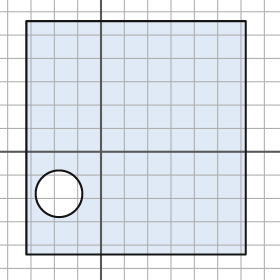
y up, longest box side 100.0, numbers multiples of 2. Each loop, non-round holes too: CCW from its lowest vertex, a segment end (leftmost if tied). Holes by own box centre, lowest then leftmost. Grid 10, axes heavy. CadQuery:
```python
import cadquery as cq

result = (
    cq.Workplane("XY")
    .moveTo(-32.0, -44.0)
    .lineTo(62.0, -44.0)
    .lineTo(62.0, 56.0)
    .lineTo(-32.0, 56.0)
    .close()
    .moveTo(-18.0, -18.0)
    .circle(10.0)
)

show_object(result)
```